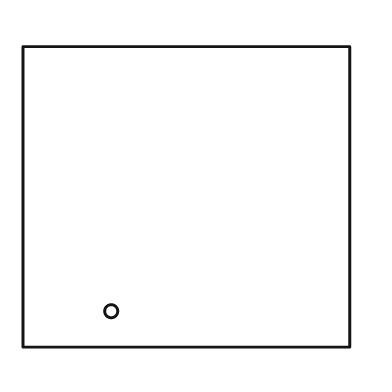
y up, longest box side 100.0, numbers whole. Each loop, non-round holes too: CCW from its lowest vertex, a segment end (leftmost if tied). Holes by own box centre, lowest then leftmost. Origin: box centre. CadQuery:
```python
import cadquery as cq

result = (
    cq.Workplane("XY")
    .moveTo(-50.0, -46.0)
    .lineTo(50.0, -46.0)
    .lineTo(50.0, 46.0)
    .lineTo(-50.0, 46.0)
    .close()
    .moveTo(-23.0, -35.0)
    .circle(2.0)
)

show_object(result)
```